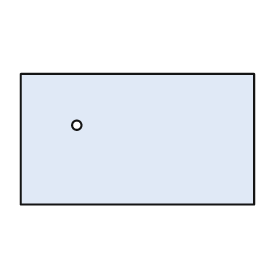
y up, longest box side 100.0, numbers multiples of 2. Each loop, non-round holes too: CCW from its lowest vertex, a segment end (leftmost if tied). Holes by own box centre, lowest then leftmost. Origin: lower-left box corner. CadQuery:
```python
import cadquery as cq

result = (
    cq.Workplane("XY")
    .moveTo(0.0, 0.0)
    .lineTo(100.0, 0.0)
    .lineTo(100.0, 56.0)
    .lineTo(0.0, 56.0)
    .close()
    .moveTo(24.0, 34.0)
    .circle(2.0)
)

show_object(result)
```